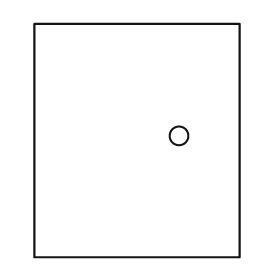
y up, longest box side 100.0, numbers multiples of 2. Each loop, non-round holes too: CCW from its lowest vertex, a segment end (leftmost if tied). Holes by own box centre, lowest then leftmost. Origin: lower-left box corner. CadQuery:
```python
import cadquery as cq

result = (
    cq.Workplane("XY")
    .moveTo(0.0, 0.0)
    .lineTo(88.0, 0.0)
    .lineTo(88.0, 100.0)
    .lineTo(0.0, 100.0)
    .close()
    .moveTo(62.0, 52.0)
    .circle(4.0)
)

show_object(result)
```